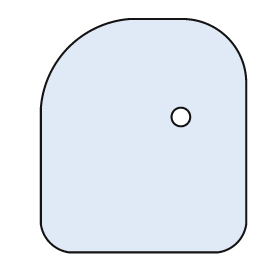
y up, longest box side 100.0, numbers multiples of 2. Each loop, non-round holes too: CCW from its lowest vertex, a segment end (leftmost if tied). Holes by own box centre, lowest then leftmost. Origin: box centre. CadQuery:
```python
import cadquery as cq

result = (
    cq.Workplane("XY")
    .moveTo(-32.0, -50.0)
    .lineTo(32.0, -50.0)
    .threePointArc((40.0, -46.0), (44.0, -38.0))
    .lineTo(44.0, 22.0)
    .threePointArc((36.0, 42.0), (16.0, 50.0))
    .lineTo(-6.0, 50.0)
    .threePointArc((-32.0, 38.0), (-44.0, 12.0))
    .lineTo(-44.0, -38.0)
    .threePointArc((-40.0, -46.0), (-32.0, -50.0))
    .close()
    .moveTo(16.0, 8.0)
    .circle(4.0)
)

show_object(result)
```